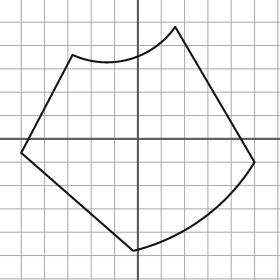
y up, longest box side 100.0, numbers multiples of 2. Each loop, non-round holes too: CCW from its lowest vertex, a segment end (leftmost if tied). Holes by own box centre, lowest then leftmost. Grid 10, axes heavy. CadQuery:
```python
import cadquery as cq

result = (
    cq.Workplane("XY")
    .moveTo(-2.0, -48.0)
    .threePointArc((28.0, -34.0), (50.0, -10.0))
    .lineTo(16.0, 48.0)
    .threePointArc((-4.0, 34.0), (-28.0, 36.0))
    .lineTo(-50.0, -6.0)
    .close()
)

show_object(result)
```